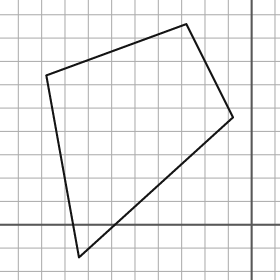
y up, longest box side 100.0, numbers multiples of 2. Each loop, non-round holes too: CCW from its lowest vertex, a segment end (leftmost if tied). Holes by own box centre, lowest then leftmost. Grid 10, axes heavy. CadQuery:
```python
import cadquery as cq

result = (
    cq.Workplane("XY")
    .moveTo(-74.0, -14.0)
    .lineTo(-8.0, 46.0)
    .lineTo(-28.0, 86.0)
    .lineTo(-88.0, 64.0)
    .close()
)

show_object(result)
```